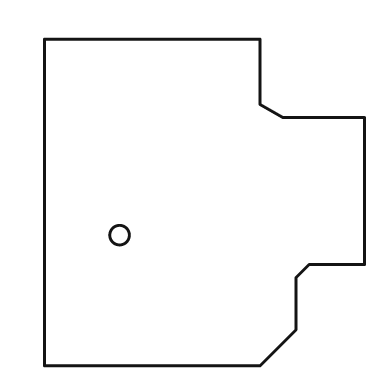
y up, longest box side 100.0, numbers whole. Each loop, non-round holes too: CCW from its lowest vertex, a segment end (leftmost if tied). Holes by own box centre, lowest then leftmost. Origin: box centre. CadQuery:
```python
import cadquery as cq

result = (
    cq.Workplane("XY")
    .moveTo(-49.0, -50.0)
    .lineTo(17.0, -50.0)
    .lineTo(28.0, -39.0)
    .lineTo(28.0, -23.0)
    .lineTo(32.0, -19.0)
    .lineTo(49.0, -19.0)
    .lineTo(49.0, 26.0)
    .lineTo(24.0, 26.0)
    .lineTo(17.0, 30.0)
    .lineTo(17.0, 50.0)
    .lineTo(-49.0, 50.0)
    .close()
    .moveTo(-26.0, -10.0)
    .circle(3.0)
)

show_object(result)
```